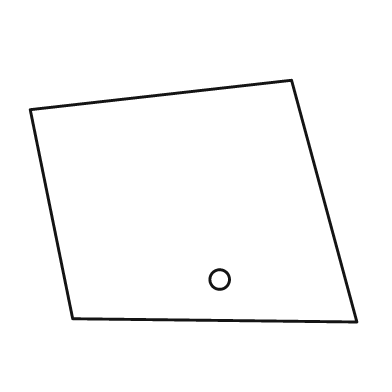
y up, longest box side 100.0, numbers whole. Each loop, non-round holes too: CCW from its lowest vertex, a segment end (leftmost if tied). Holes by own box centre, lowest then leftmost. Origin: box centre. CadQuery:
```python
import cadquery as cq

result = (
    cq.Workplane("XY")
    .moveTo(50.0, -37.0)
    .lineTo(30.0, 37.0)
    .lineTo(-50.0, 28.0)
    .lineTo(-37.0, -36.0)
    .close()
    .moveTo(8.0, -24.0)
    .circle(3.0)
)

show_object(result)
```